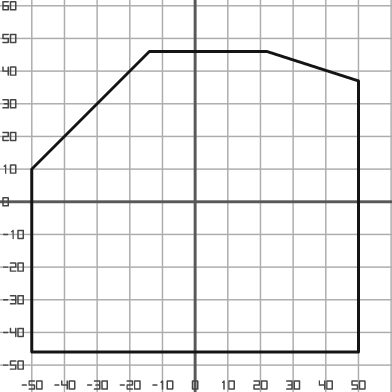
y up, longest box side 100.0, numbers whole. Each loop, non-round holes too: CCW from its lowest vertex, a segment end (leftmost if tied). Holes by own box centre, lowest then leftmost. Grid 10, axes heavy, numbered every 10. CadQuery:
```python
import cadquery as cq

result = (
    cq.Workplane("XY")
    .moveTo(-50.0, -46.0)
    .lineTo(50.0, -46.0)
    .lineTo(50.0, 37.0)
    .lineTo(22.0, 46.0)
    .lineTo(-14.0, 46.0)
    .lineTo(-50.0, 10.0)
    .close()
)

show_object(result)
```